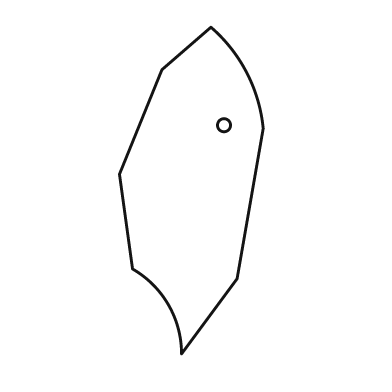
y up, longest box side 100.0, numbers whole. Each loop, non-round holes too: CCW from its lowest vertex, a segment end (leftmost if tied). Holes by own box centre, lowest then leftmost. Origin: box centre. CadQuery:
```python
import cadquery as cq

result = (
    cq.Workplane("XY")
    .moveTo(-3.0, -50.0)
    .lineTo(14.0, -27.0)
    .lineTo(22.0, 19.0)
    .threePointArc((17.0, 36.0), (6.0, 50.0))
    .lineTo(-9.0, 37.0)
    .lineTo(-22.0, 5.0)
    .lineTo(-18.0, -24.0)
    .threePointArc((-7.0, -35.0), (-3.0, -50.0))
    .close()
    .moveTo(10.0, 20.0)
    .circle(2.0)
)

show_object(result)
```